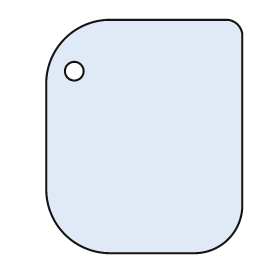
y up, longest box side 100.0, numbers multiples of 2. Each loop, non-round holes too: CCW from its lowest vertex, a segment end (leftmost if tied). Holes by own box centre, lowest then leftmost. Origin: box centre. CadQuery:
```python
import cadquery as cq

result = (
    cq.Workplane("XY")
    .moveTo(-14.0, -50.0)
    .lineTo(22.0, -50.0)
    .threePointArc((36.0, -44.0), (42.0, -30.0))
    .lineTo(42.0, 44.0)
    .threePointArc((40.0, 48.0), (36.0, 50.0))
    .lineTo(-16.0, 50.0)
    .threePointArc((-34.0, 42.0), (-42.0, 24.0))
    .lineTo(-42.0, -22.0)
    .threePointArc((-34.0, -42.0), (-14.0, -50.0))
    .close()
    .moveTo(-30.0, 28.0)
    .circle(4.0)
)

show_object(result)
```